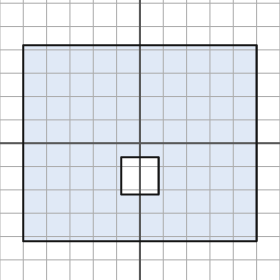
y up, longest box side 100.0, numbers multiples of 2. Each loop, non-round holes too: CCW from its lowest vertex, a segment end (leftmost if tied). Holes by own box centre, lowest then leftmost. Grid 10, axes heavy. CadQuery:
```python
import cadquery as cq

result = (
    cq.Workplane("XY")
    .moveTo(-50.0, -42.0)
    .lineTo(50.0, -42.0)
    .lineTo(50.0, 42.0)
    .lineTo(-50.0, 42.0)
    .close()
    .moveTo(-8.0, -22.0)
    .lineTo(8.0, -22.0)
    .lineTo(8.0, -6.0)
    .lineTo(-8.0, -6.0)
    .close()
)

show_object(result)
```